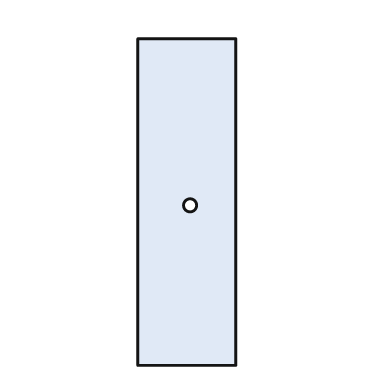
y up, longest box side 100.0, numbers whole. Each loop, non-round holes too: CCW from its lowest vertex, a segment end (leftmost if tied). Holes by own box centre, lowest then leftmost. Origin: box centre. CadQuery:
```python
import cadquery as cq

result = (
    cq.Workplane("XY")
    .moveTo(-15.0, -50.0)
    .lineTo(15.0, -50.0)
    .lineTo(15.0, 50.0)
    .lineTo(-15.0, 50.0)
    .close()
    .moveTo(1.0, -1.0)
    .circle(2.0)
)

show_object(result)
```